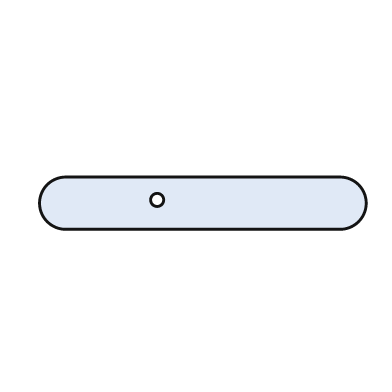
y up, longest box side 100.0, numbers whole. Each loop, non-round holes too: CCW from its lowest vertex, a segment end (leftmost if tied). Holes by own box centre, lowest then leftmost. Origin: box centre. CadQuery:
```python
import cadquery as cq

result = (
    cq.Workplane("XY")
    .moveTo(-42.0, -8.0)
    .lineTo(42.0, -8.0)
    .threePointArc((50.0, 0.0), (42.0, 8.0))
    .lineTo(-42.0, 8.0)
    .threePointArc((-50.0, 0.0), (-42.0, -8.0))
    .close()
    .moveTo(-14.0, 1.0)
    .circle(2.0)
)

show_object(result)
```